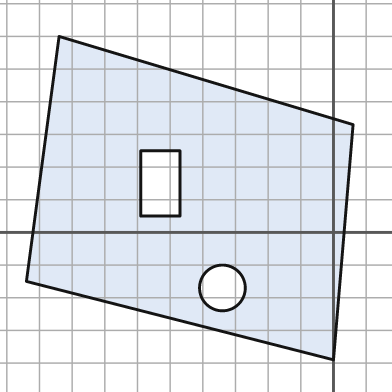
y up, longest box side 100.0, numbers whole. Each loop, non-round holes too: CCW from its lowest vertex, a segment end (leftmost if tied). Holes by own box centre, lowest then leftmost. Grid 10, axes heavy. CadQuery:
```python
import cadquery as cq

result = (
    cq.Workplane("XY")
    .moveTo(0.0, -39.0)
    .lineTo(6.0, 33.0)
    .lineTo(-84.0, 60.0)
    .lineTo(-94.0, -15.0)
    .close()
    .moveTo(-34.0, -17.0)
    .circle(7.0)
    .moveTo(-59.0, 5.0)
    .lineTo(-47.0, 5.0)
    .lineTo(-47.0, 25.0)
    .lineTo(-59.0, 25.0)
    .close()
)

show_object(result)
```